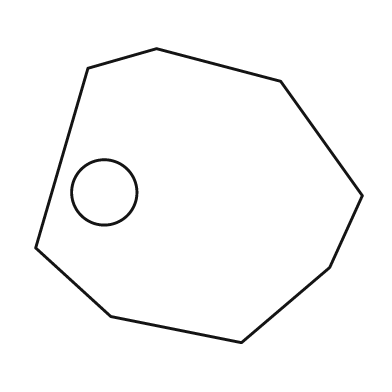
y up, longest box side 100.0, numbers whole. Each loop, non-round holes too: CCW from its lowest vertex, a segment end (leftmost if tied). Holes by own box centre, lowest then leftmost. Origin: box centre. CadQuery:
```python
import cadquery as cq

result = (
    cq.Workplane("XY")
    .moveTo(13.0, -45.0)
    .lineTo(40.0, -22.0)
    .lineTo(50.0, 0.0)
    .lineTo(25.0, 35.0)
    .lineTo(-13.0, 45.0)
    .lineTo(-34.0, 39.0)
    .lineTo(-50.0, -16.0)
    .lineTo(-27.0, -37.0)
    .close()
    .moveTo(-29.0, 1.0)
    .circle(10.0)
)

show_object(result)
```